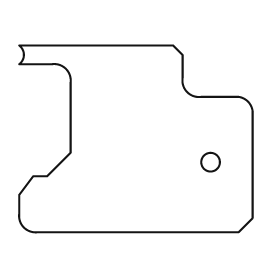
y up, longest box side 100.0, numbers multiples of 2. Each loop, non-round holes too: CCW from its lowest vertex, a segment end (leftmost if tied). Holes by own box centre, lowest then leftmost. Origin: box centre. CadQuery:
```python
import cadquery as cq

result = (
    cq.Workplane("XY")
    .moveTo(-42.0, -40.0)
    .lineTo(44.0, -40.0)
    .lineTo(50.0, -34.0)
    .lineTo(50.0, 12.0)
    .threePointArc((48.0, 16.0), (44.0, 18.0))
    .lineTo(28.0, 18.0)
    .threePointArc((22.0, 20.0), (20.0, 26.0))
    .lineTo(20.0, 36.0)
    .lineTo(16.0, 40.0)
    .lineTo(-50.0, 40.0)
    .threePointArc((-48.0, 36.0), (-50.0, 32.0))
    .lineTo(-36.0, 32.0)
    .threePointArc((-30.0, 30.0), (-28.0, 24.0))
    .lineTo(-28.0, -6.0)
    .lineTo(-38.0, -16.0)
    .lineTo(-44.0, -16.0)
    .lineTo(-50.0, -24.0)
    .lineTo(-50.0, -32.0)
    .threePointArc((-48.0, -38.0), (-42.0, -40.0))
    .close()
    .moveTo(32.0, -10.0)
    .circle(4.0)
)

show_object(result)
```